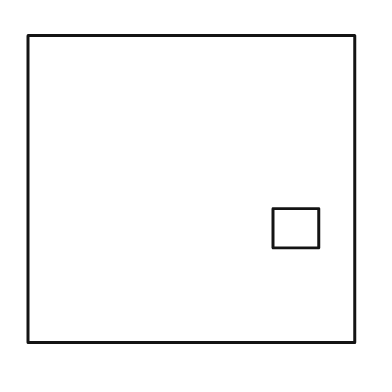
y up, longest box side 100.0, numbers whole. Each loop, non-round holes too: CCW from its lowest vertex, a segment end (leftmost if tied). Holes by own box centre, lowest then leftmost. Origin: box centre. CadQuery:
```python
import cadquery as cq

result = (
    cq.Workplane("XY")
    .moveTo(-50.0, -47.0)
    .lineTo(50.0, -47.0)
    .lineTo(50.0, 47.0)
    .lineTo(-50.0, 47.0)
    .close()
    .moveTo(25.0, -18.0)
    .lineTo(39.0, -18.0)
    .lineTo(39.0, -6.0)
    .lineTo(25.0, -6.0)
    .close()
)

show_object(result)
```